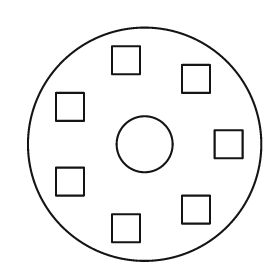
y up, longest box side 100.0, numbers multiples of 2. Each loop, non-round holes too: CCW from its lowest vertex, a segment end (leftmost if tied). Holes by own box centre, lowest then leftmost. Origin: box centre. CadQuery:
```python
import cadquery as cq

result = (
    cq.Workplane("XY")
    .moveTo(0.0, 0.0)
    .circle(50.0)
    .moveTo(-14.0, -42.0)
    .lineTo(-2.0, -42.0)
    .lineTo(-2.0, -30.0)
    .lineTo(-14.0, -30.0)
    .close()
    .moveTo(16.0, -34.0)
    .lineTo(28.0, -34.0)
    .lineTo(28.0, -22.0)
    .lineTo(16.0, -22.0)
    .close()
    .moveTo(-38.0, -22.0)
    .lineTo(-26.0, -22.0)
    .lineTo(-26.0, -10.0)
    .lineTo(-38.0, -10.0)
    .close()
    .moveTo(0.0, 0.0)
    .circle(12.0)
    .moveTo(30.0, -6.0)
    .lineTo(42.0, -6.0)
    .lineTo(42.0, 6.0)
    .lineTo(30.0, 6.0)
    .close()
    .moveTo(-38.0, 10.0)
    .lineTo(-26.0, 10.0)
    .lineTo(-26.0, 22.0)
    .lineTo(-38.0, 22.0)
    .close()
    .moveTo(16.0, 22.0)
    .lineTo(28.0, 22.0)
    .lineTo(28.0, 34.0)
    .lineTo(16.0, 34.0)
    .close()
    .moveTo(-14.0, 30.0)
    .lineTo(-2.0, 30.0)
    .lineTo(-2.0, 42.0)
    .lineTo(-14.0, 42.0)
    .close()
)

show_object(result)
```